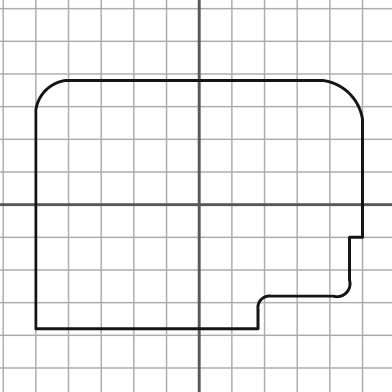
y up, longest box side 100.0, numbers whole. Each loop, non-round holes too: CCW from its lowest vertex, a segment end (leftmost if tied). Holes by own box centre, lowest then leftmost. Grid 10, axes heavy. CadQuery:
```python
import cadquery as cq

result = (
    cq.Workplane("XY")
    .moveTo(-50.0, -38.0)
    .lineTo(18.0, -38.0)
    .lineTo(18.0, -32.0)
    .threePointArc((19.0, -29.0), (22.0, -28.0))
    .lineTo(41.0, -28.0)
    .threePointArc((45.0, -27.0), (46.0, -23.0))
    .lineTo(46.0, -10.0)
    .lineTo(50.0, -10.0)
    .lineTo(50.0, 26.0)
    .threePointArc((46.0, 34.0), (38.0, 38.0))
    .lineTo(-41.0, 38.0)
    .threePointArc((-47.0, 35.0), (-50.0, 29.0))
    .close()
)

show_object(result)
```